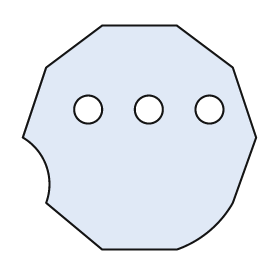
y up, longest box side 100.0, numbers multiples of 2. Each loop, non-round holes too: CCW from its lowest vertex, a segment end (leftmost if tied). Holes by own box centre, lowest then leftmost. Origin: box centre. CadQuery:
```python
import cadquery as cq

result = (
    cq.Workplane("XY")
    .moveTo(-16.0, -48.0)
    .lineTo(16.0, -48.0)
    .threePointArc((30.0, -40.0), (40.0, -28.0))
    .lineTo(50.0, 0.0)
    .lineTo(40.0, 30.0)
    .lineTo(16.0, 48.0)
    .lineTo(-16.0, 48.0)
    .lineTo(-40.0, 30.0)
    .lineTo(-50.0, 0.0)
    .threePointArc((-40.0, -12.0), (-40.0, -28.0))
    .close()
    .moveTo(-22.0, 12.0)
    .circle(6.0)
    .moveTo(4.0, 12.0)
    .circle(6.0)
    .moveTo(30.0, 12.0)
    .circle(6.0)
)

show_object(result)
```